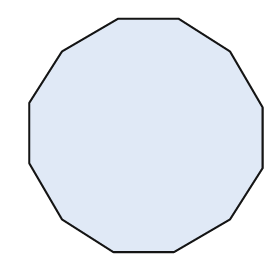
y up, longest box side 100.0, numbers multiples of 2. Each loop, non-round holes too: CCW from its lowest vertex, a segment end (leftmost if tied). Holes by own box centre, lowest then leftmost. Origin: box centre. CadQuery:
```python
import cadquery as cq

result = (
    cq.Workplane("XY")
    .moveTo(-14.0, -50.0)
    .lineTo(12.0, -50.0)
    .lineTo(36.0, -36.0)
    .lineTo(50.0, -14.0)
    .lineTo(50.0, 12.0)
    .lineTo(36.0, 36.0)
    .lineTo(14.0, 50.0)
    .lineTo(-12.0, 50.0)
    .lineTo(-36.0, 36.0)
    .lineTo(-50.0, 14.0)
    .lineTo(-50.0, -12.0)
    .lineTo(-36.0, -36.0)
    .close()
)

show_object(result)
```